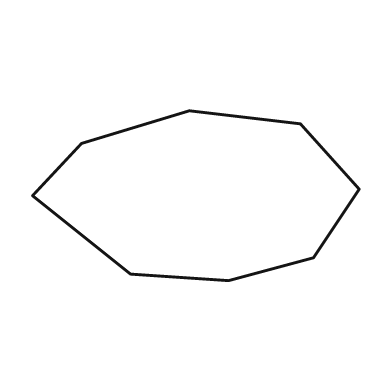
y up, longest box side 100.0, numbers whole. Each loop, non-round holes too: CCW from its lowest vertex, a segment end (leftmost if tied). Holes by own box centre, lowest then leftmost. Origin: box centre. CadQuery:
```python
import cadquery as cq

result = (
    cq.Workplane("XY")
    .moveTo(10.0, -26.0)
    .lineTo(36.0, -19.0)
    .lineTo(50.0, 2.0)
    .lineTo(32.0, 22.0)
    .lineTo(-2.0, 26.0)
    .lineTo(-35.0, 16.0)
    .lineTo(-50.0, 0.0)
    .lineTo(-20.0, -24.0)
    .close()
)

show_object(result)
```